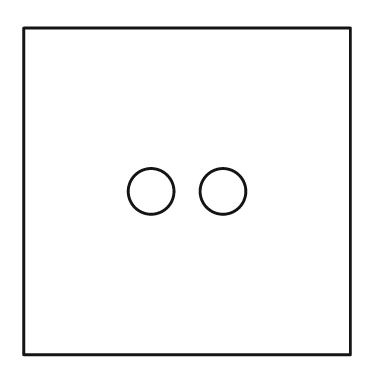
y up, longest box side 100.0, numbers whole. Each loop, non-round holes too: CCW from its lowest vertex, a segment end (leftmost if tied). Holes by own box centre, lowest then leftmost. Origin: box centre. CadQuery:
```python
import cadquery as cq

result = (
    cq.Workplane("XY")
    .moveTo(-50.0, -50.0)
    .lineTo(50.0, -50.0)
    .lineTo(50.0, 50.0)
    .lineTo(-50.0, 50.0)
    .close()
    .moveTo(-11.0, 0.0)
    .circle(7.0)
    .moveTo(11.0, 0.0)
    .circle(7.0)
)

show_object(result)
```